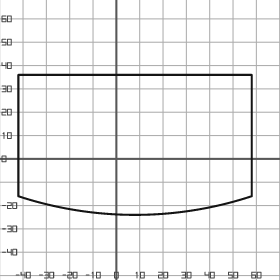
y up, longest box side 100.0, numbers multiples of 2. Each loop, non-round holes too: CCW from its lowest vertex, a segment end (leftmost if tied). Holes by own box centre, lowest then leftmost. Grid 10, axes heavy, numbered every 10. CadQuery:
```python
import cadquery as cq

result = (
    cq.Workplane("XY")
    .moveTo(-42.0, -16.0)
    .threePointArc((8.0, -24.0), (58.0, -16.0))
    .lineTo(58.0, 36.0)
    .lineTo(-42.0, 36.0)
    .close()
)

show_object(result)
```